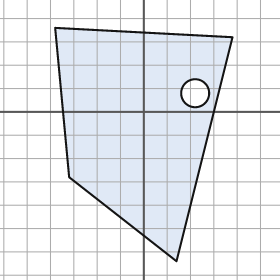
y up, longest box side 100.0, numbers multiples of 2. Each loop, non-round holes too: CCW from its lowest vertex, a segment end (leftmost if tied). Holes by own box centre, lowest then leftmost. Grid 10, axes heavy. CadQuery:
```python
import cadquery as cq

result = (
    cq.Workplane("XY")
    .moveTo(14.0, -64.0)
    .lineTo(38.0, 32.0)
    .lineTo(-38.0, 36.0)
    .lineTo(-32.0, -28.0)
    .close()
    .moveTo(22.0, 8.0)
    .circle(6.0)
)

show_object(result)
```